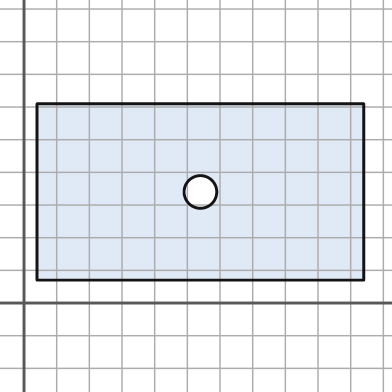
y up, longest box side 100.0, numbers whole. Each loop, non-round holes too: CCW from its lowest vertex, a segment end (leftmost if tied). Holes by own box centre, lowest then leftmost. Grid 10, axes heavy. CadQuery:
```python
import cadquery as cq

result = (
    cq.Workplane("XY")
    .moveTo(4.0, 7.0)
    .lineTo(104.0, 7.0)
    .lineTo(104.0, 61.0)
    .lineTo(4.0, 61.0)
    .close()
    .moveTo(54.0, 34.0)
    .circle(5.0)
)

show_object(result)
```